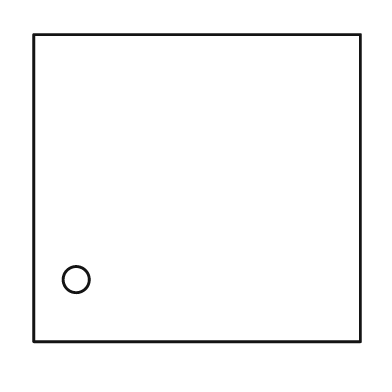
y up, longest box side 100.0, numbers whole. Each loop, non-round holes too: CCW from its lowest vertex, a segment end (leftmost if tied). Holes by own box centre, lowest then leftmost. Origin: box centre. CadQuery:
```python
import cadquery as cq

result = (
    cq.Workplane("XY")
    .moveTo(-50.0, -47.0)
    .lineTo(50.0, -47.0)
    .lineTo(50.0, 47.0)
    .lineTo(-50.0, 47.0)
    .close()
    .moveTo(-37.0, -28.0)
    .circle(4.0)
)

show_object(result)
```